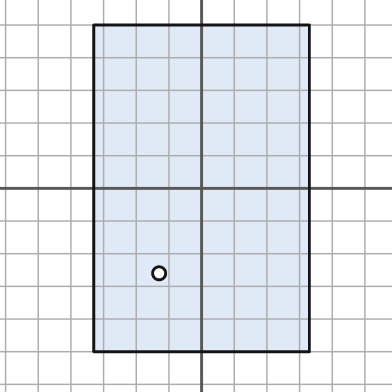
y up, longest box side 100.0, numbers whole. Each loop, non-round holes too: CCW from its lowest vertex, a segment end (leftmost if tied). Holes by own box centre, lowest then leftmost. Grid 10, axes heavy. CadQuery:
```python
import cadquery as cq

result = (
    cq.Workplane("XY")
    .moveTo(-33.0, -50.0)
    .lineTo(33.0, -50.0)
    .lineTo(33.0, 50.0)
    .lineTo(-33.0, 50.0)
    .close()
    .moveTo(-13.0, -26.0)
    .circle(2.0)
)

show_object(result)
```